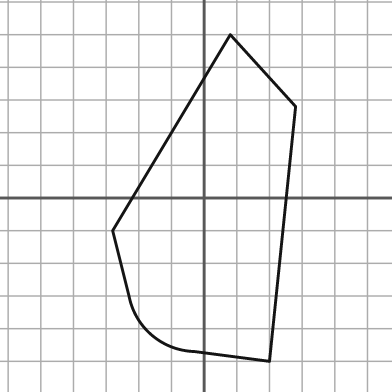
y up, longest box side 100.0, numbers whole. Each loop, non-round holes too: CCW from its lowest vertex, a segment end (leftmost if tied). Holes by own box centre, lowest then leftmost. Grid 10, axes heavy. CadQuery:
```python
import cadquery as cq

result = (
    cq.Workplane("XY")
    .moveTo(20.0, -50.0)
    .lineTo(28.0, 28.0)
    .lineTo(8.0, 50.0)
    .lineTo(-28.0, -10.0)
    .lineTo(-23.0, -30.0)
    .threePointArc((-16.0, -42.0), (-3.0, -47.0))
    .close()
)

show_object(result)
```